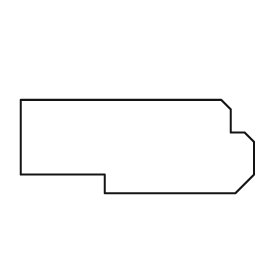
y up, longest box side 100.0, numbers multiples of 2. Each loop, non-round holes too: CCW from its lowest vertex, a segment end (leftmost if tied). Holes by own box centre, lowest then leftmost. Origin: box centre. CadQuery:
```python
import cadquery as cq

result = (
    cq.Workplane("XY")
    .moveTo(-14.0, -20.0)
    .lineTo(42.0, -20.0)
    .lineTo(50.0, -12.0)
    .lineTo(50.0, 2.0)
    .lineTo(46.0, 6.0)
    .lineTo(40.0, 6.0)
    .lineTo(40.0, 16.0)
    .lineTo(36.0, 20.0)
    .lineTo(-50.0, 20.0)
    .lineTo(-50.0, -12.0)
    .lineTo(-14.0, -12.0)
    .close()
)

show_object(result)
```